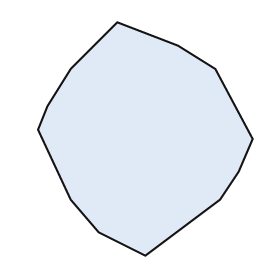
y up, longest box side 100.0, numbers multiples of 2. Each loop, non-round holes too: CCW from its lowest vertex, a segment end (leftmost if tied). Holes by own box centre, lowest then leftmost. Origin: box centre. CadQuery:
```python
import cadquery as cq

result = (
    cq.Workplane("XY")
    .moveTo(0.0, -50.0)
    .lineTo(32.0, -26.0)
    .lineTo(40.0, -14.0)
    .lineTo(46.0, 0.0)
    .lineTo(30.0, 30.0)
    .lineTo(14.0, 40.0)
    .lineTo(-12.0, 50.0)
    .lineTo(-32.0, 30.0)
    .lineTo(-42.0, 14.0)
    .lineTo(-46.0, 4.0)
    .lineTo(-32.0, -26.0)
    .lineTo(-20.0, -40.0)
    .close()
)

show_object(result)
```